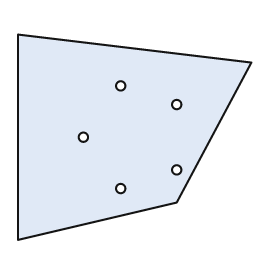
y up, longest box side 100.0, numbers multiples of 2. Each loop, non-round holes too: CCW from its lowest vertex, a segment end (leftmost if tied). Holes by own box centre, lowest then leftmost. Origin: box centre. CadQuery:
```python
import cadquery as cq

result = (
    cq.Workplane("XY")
    .moveTo(-50.0, -44.0)
    .lineTo(18.0, -28.0)
    .lineTo(50.0, 32.0)
    .lineTo(-50.0, 44.0)
    .close()
    .moveTo(-6.0, -22.0)
    .circle(2.0)
    .moveTo(18.0, -14.0)
    .circle(2.0)
    .moveTo(-22.0, 0.0)
    .circle(2.0)
    .moveTo(18.0, 14.0)
    .circle(2.0)
    .moveTo(-6.0, 22.0)
    .circle(2.0)
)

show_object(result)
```